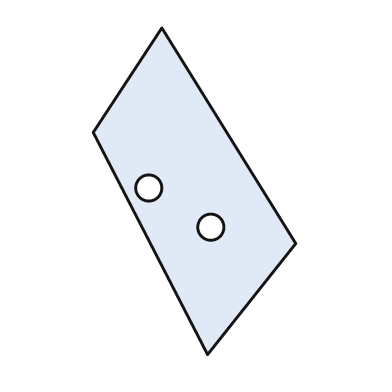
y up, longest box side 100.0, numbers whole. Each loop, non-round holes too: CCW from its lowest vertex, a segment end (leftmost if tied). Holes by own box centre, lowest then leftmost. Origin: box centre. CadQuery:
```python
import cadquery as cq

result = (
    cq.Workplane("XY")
    .moveTo(4.0, -50.0)
    .lineTo(31.0, -16.0)
    .lineTo(-10.0, 50.0)
    .lineTo(-31.0, 18.0)
    .close()
    .moveTo(5.0, -11.0)
    .circle(4.0)
    .moveTo(-14.0, 1.0)
    .circle(4.0)
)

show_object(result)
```